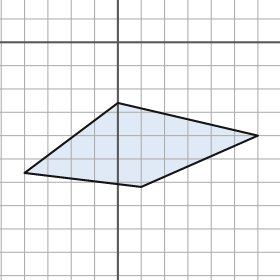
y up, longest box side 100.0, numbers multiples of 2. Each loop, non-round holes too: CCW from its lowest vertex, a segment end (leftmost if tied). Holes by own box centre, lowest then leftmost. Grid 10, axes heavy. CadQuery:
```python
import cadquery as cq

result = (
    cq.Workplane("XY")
    .moveTo(10.0, -62.0)
    .lineTo(60.0, -40.0)
    .lineTo(0.0, -26.0)
    .lineTo(-40.0, -56.0)
    .close()
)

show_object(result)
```